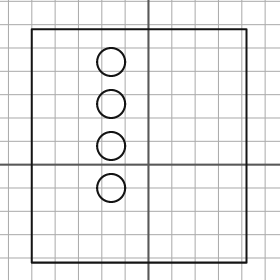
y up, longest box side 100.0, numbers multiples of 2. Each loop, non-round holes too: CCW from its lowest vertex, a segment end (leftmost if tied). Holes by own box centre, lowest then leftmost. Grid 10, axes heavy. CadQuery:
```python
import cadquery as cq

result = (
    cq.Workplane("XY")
    .moveTo(-50.0, -42.0)
    .lineTo(42.0, -42.0)
    .lineTo(42.0, 58.0)
    .lineTo(-50.0, 58.0)
    .close()
    .moveTo(-16.0, -10.0)
    .circle(6.0)
    .moveTo(-16.0, 8.0)
    .circle(6.0)
    .moveTo(-16.0, 26.0)
    .circle(6.0)
    .moveTo(-16.0, 44.0)
    .circle(6.0)
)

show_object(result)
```